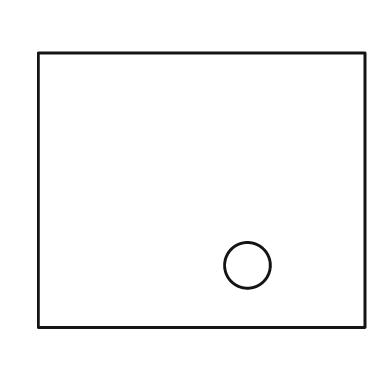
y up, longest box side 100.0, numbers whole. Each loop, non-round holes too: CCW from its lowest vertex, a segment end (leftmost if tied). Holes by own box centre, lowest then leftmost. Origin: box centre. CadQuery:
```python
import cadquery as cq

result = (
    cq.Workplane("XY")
    .moveTo(-50.0, -42.0)
    .lineTo(50.0, -42.0)
    .lineTo(50.0, 42.0)
    .lineTo(-50.0, 42.0)
    .close()
    .moveTo(14.0, -23.0)
    .circle(7.0)
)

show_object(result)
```